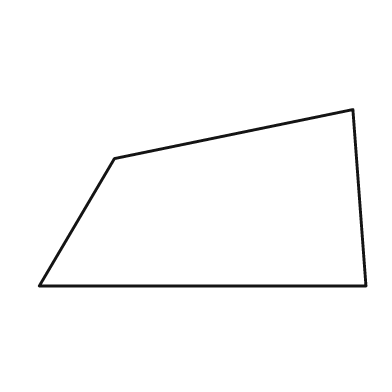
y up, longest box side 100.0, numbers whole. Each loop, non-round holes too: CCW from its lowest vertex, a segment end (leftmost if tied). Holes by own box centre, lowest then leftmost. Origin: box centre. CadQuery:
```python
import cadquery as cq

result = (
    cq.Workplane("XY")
    .moveTo(-50.0, -27.0)
    .lineTo(50.0, -27.0)
    .lineTo(46.0, 27.0)
    .lineTo(-27.0, 12.0)
    .close()
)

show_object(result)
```